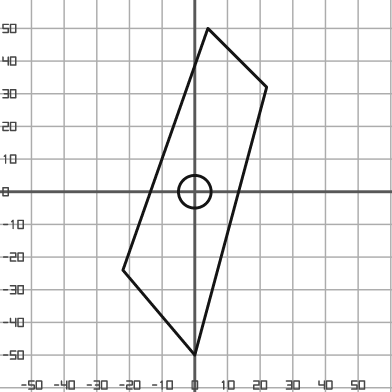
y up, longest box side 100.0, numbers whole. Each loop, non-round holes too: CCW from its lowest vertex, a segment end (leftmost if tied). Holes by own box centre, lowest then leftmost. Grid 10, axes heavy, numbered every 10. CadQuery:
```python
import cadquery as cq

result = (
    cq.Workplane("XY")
    .moveTo(0.0, -50.0)
    .lineTo(22.0, 32.0)
    .lineTo(4.0, 50.0)
    .lineTo(-22.0, -24.0)
    .close()
    .moveTo(0.0, 0.0)
    .circle(5.0)
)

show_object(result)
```